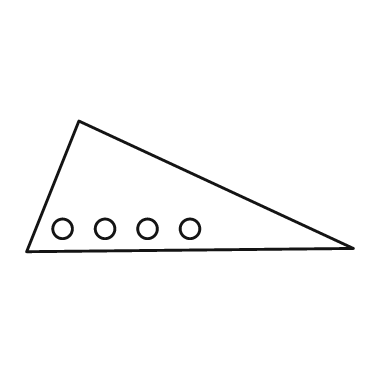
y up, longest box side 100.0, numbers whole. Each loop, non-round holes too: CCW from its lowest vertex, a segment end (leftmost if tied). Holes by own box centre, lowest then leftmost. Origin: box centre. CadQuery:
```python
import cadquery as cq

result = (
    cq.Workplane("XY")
    .moveTo(-50.0, -20.0)
    .lineTo(50.0, -19.0)
    .lineTo(-34.0, 20.0)
    .close()
    .moveTo(-39.0, -13.0)
    .circle(3.0)
    .moveTo(-26.0, -13.0)
    .circle(3.0)
    .moveTo(-13.0, -13.0)
    .circle(3.0)
    .moveTo(0.0, -13.0)
    .circle(3.0)
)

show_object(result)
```